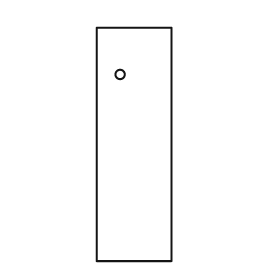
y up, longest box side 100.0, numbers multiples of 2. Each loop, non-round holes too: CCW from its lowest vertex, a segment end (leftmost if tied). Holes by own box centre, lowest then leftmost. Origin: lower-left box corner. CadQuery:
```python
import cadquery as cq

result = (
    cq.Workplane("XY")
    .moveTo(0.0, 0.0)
    .lineTo(32.0, 0.0)
    .lineTo(32.0, 100.0)
    .lineTo(0.0, 100.0)
    .close()
    .moveTo(10.0, 80.0)
    .circle(2.0)
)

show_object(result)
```